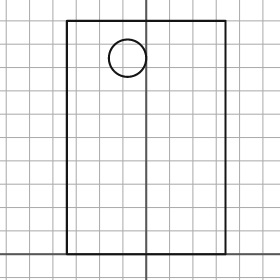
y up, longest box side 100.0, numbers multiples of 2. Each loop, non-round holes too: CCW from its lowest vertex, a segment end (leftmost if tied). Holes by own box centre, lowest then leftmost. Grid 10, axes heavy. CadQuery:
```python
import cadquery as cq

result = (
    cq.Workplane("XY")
    .moveTo(-34.0, 0.0)
    .lineTo(34.0, 0.0)
    .lineTo(34.0, 100.0)
    .lineTo(-34.0, 100.0)
    .close()
    .moveTo(-8.0, 84.0)
    .circle(8.0)
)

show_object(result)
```